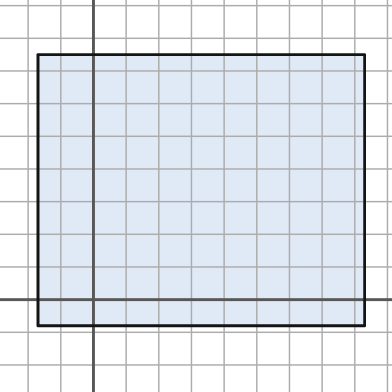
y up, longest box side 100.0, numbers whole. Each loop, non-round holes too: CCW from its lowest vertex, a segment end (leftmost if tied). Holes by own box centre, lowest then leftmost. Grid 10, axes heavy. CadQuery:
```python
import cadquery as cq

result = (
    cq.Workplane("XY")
    .moveTo(-17.0, -8.0)
    .lineTo(83.0, -8.0)
    .lineTo(83.0, 75.0)
    .lineTo(-17.0, 75.0)
    .close()
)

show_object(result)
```